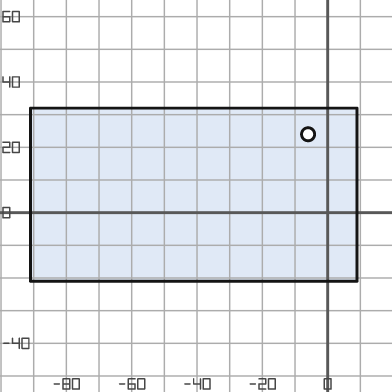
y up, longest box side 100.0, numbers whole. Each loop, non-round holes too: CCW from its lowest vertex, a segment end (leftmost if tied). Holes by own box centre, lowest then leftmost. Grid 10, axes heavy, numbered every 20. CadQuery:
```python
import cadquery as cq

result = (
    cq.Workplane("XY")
    .moveTo(-91.0, -21.0)
    .lineTo(9.0, -21.0)
    .lineTo(9.0, 32.0)
    .lineTo(-91.0, 32.0)
    .close()
    .moveTo(-6.0, 24.0)
    .circle(2.0)
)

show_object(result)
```